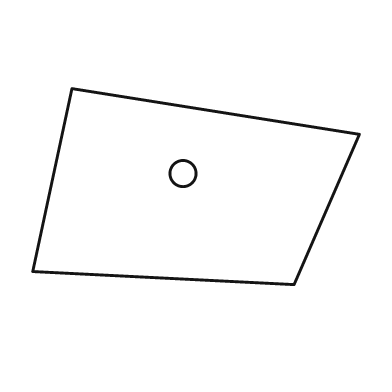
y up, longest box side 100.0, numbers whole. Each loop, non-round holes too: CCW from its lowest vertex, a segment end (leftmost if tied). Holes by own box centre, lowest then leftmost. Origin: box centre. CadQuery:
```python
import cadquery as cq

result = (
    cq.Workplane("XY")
    .moveTo(30.0, -30.0)
    .lineTo(50.0, 16.0)
    .lineTo(-38.0, 30.0)
    .lineTo(-50.0, -26.0)
    .close()
    .moveTo(-4.0, 4.0)
    .circle(4.0)
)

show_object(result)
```